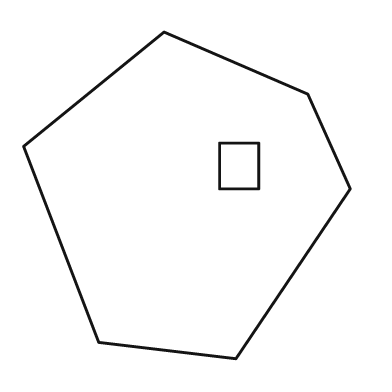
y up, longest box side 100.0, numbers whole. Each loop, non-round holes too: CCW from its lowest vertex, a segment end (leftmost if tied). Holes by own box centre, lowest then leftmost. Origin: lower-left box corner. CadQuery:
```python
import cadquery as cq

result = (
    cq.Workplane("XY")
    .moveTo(65.0, 0.0)
    .lineTo(100.0, 52.0)
    .lineTo(87.0, 81.0)
    .lineTo(43.0, 100.0)
    .lineTo(0.0, 65.0)
    .lineTo(23.0, 5.0)
    .close()
    .moveTo(60.0, 52.0)
    .lineTo(72.0, 52.0)
    .lineTo(72.0, 66.0)
    .lineTo(60.0, 66.0)
    .close()
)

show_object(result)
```